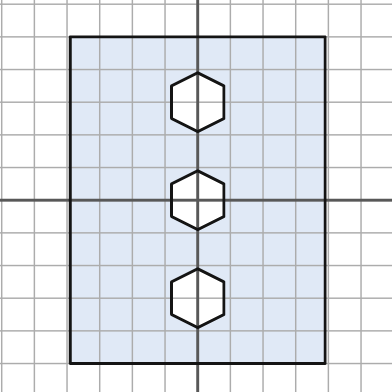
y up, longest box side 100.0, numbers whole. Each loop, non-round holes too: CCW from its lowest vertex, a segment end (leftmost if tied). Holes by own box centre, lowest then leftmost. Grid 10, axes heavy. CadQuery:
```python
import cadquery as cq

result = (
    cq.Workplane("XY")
    .moveTo(-39.0, -50.0)
    .lineTo(39.0, -50.0)
    .lineTo(39.0, 50.0)
    .lineTo(-39.0, 50.0)
    .close()
    .moveTo(0.0, -39.0)
    .lineTo(8.0, -35.0)
    .lineTo(8.0, -25.0)
    .lineTo(0.0, -21.0)
    .lineTo(-8.0, -25.0)
    .lineTo(-8.0, -35.0)
    .close()
    .moveTo(0.0, -9.0)
    .lineTo(8.0, -5.0)
    .lineTo(8.0, 5.0)
    .lineTo(0.0, 9.0)
    .lineTo(-8.0, 5.0)
    .lineTo(-8.0, -5.0)
    .close()
    .moveTo(0.0, 21.0)
    .lineTo(8.0, 25.0)
    .lineTo(8.0, 35.0)
    .lineTo(0.0, 39.0)
    .lineTo(-8.0, 35.0)
    .lineTo(-8.0, 25.0)
    .close()
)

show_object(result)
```